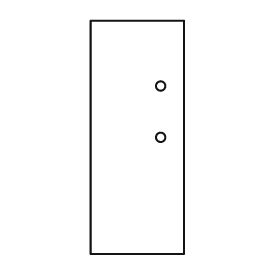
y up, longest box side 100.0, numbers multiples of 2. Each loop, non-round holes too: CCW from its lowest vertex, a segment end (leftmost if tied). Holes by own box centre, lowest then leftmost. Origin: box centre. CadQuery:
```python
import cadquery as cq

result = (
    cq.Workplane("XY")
    .moveTo(-20.0, -50.0)
    .lineTo(20.0, -50.0)
    .lineTo(20.0, 50.0)
    .lineTo(-20.0, 50.0)
    .close()
    .moveTo(10.0, 0.0)
    .circle(2.0)
    .moveTo(10.0, 22.0)
    .circle(2.0)
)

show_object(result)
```